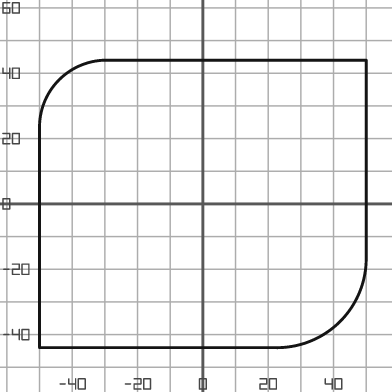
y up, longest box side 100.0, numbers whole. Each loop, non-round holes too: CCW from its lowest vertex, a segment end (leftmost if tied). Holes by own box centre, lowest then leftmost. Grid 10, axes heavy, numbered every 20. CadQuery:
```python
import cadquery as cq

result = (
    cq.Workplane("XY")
    .moveTo(-50.0, -44.0)
    .lineTo(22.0, -44.0)
    .threePointArc((42.0, -36.0), (50.0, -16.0))
    .lineTo(50.0, 44.0)
    .lineTo(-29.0, 44.0)
    .threePointArc((-44.0, 38.0), (-50.0, 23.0))
    .close()
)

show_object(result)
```